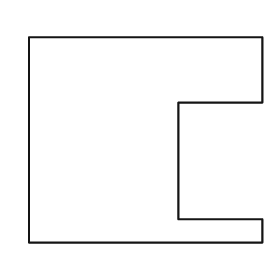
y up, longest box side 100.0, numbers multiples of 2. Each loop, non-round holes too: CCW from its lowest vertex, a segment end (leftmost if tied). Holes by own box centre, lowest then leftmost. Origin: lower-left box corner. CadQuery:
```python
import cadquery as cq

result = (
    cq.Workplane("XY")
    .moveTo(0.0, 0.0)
    .lineTo(100.0, 0.0)
    .lineTo(100.0, 10.0)
    .lineTo(64.0, 10.0)
    .lineTo(64.0, 60.0)
    .lineTo(100.0, 60.0)
    .lineTo(100.0, 88.0)
    .lineTo(0.0, 88.0)
    .close()
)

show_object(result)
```